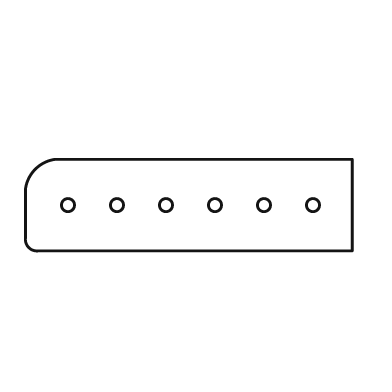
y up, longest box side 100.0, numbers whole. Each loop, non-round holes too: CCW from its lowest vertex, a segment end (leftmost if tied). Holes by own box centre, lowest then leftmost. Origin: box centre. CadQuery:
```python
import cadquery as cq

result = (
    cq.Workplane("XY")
    .moveTo(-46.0, -14.0)
    .lineTo(50.0, -14.0)
    .lineTo(50.0, 14.0)
    .lineTo(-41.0, 14.0)
    .threePointArc((-47.0, 11.0), (-50.0, 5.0))
    .lineTo(-50.0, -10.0)
    .threePointArc((-49.0, -13.0), (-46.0, -14.0))
    .close()
    .moveTo(-37.0, 0.0)
    .circle(2.0)
    .moveTo(-22.0, 0.0)
    .circle(2.0)
    .moveTo(-7.0, 0.0)
    .circle(2.0)
    .moveTo(8.0, 0.0)
    .circle(2.0)
    .moveTo(23.0, 0.0)
    .circle(2.0)
    .moveTo(38.0, 0.0)
    .circle(2.0)
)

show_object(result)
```